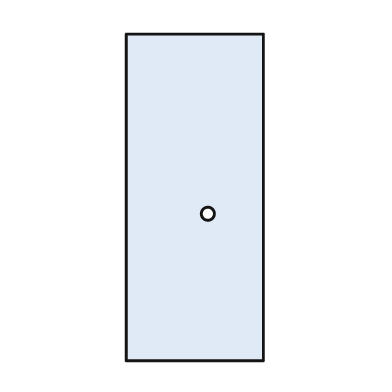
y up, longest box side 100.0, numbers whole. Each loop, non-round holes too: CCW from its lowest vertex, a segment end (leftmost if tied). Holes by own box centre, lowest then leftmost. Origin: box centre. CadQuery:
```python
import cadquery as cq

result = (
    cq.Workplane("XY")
    .moveTo(-21.0, -50.0)
    .lineTo(21.0, -50.0)
    .lineTo(21.0, 50.0)
    .lineTo(-21.0, 50.0)
    .close()
    .moveTo(4.0, -5.0)
    .circle(2.0)
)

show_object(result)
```